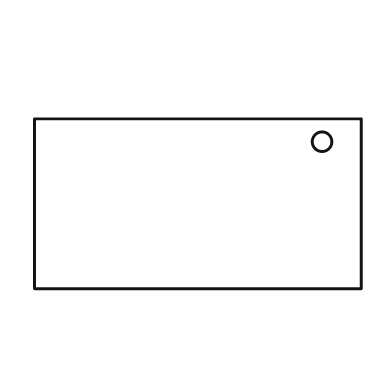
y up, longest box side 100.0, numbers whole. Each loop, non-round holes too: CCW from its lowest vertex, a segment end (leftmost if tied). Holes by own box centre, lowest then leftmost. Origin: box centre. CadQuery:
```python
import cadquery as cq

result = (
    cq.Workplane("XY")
    .moveTo(-50.0, -26.0)
    .lineTo(50.0, -26.0)
    .lineTo(50.0, 26.0)
    .lineTo(-50.0, 26.0)
    .close()
    .moveTo(38.0, 19.0)
    .circle(3.0)
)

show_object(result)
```